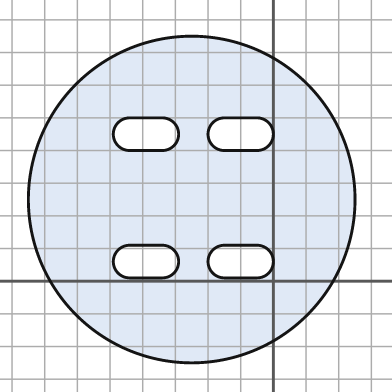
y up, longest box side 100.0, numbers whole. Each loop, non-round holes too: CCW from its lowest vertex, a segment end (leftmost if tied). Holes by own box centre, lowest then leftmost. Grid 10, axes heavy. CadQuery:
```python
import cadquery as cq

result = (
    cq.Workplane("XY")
    .moveTo(-25.0, 25.0)
    .circle(50.0)
    .moveTo(-44.0, 1.0)
    .lineTo(-34.0, 1.0)
    .threePointArc((-29.0, 6.0), (-34.0, 11.0))
    .lineTo(-44.0, 11.0)
    .threePointArc((-49.0, 6.0), (-44.0, 1.0))
    .close()
    .moveTo(-15.0, 1.0)
    .lineTo(-5.0, 1.0)
    .threePointArc((0.0, 6.0), (-5.0, 11.0))
    .lineTo(-15.0, 11.0)
    .threePointArc((-20.0, 6.0), (-15.0, 1.0))
    .close()
    .moveTo(-44.0, 40.0)
    .lineTo(-34.0, 40.0)
    .threePointArc((-29.0, 45.0), (-34.0, 50.0))
    .lineTo(-44.0, 50.0)
    .threePointArc((-49.0, 45.0), (-44.0, 40.0))
    .close()
    .moveTo(-15.0, 40.0)
    .lineTo(-5.0, 40.0)
    .threePointArc((0.0, 45.0), (-5.0, 50.0))
    .lineTo(-15.0, 50.0)
    .threePointArc((-20.0, 45.0), (-15.0, 40.0))
    .close()
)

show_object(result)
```